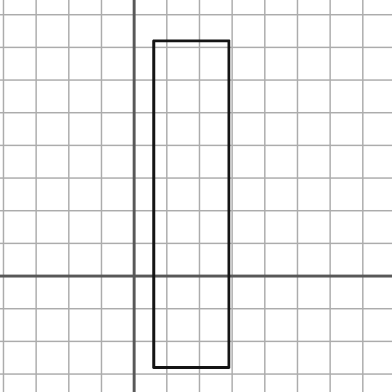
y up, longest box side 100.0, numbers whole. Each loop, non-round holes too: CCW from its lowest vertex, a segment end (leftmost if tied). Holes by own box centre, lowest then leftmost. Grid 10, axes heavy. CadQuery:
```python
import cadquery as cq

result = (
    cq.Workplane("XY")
    .moveTo(6.0, -28.0)
    .lineTo(29.0, -28.0)
    .lineTo(29.0, 72.0)
    .lineTo(6.0, 72.0)
    .close()
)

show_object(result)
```